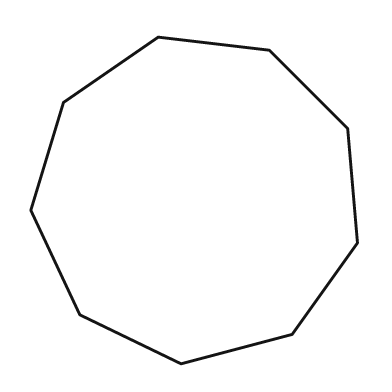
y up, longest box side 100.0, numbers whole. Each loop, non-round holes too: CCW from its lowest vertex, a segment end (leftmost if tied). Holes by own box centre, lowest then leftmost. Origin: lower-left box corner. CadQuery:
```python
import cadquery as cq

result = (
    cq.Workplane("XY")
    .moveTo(46.0, 0.0)
    .lineTo(80.0, 9.0)
    .lineTo(100.0, 37.0)
    .lineTo(97.0, 72.0)
    .lineTo(73.0, 96.0)
    .lineTo(39.0, 100.0)
    .lineTo(10.0, 80.0)
    .lineTo(0.0, 47.0)
    .lineTo(15.0, 15.0)
    .close()
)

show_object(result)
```